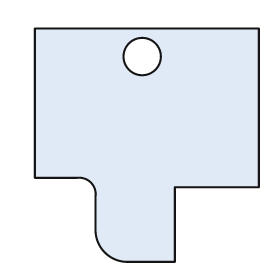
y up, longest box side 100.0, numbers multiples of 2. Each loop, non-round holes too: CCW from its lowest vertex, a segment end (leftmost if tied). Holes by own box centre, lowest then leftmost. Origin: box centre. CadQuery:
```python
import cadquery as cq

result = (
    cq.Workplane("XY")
    .moveTo(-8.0, -50.0)
    .lineTo(12.0, -50.0)
    .lineTo(12.0, -18.0)
    .lineTo(48.0, -18.0)
    .lineTo(48.0, 50.0)
    .lineTo(-48.0, 50.0)
    .lineTo(-48.0, -14.0)
    .lineTo(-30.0, -14.0)
    .threePointArc((-24.0, -16.0), (-22.0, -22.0))
    .lineTo(-22.0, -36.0)
    .threePointArc((-18.0, -46.0), (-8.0, -50.0))
    .close()
    .moveTo(-2.0, 38.0)
    .circle(8.0)
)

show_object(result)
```